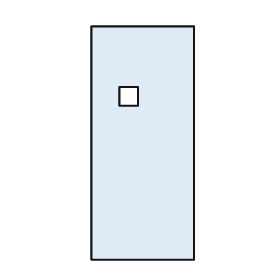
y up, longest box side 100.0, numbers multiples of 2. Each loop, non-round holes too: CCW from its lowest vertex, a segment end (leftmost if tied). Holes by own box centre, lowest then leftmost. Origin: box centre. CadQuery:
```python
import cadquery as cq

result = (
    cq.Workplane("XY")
    .moveTo(-22.0, -50.0)
    .lineTo(22.0, -50.0)
    .lineTo(22.0, 50.0)
    .lineTo(-22.0, 50.0)
    .close()
    .moveTo(-10.0, 16.0)
    .lineTo(-2.0, 16.0)
    .lineTo(-2.0, 24.0)
    .lineTo(-10.0, 24.0)
    .close()
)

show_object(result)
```